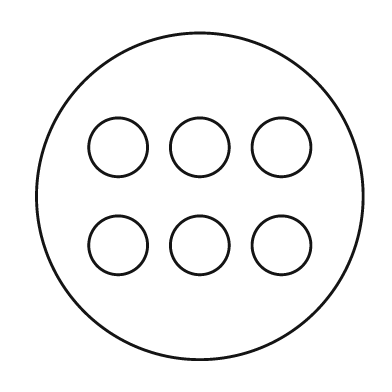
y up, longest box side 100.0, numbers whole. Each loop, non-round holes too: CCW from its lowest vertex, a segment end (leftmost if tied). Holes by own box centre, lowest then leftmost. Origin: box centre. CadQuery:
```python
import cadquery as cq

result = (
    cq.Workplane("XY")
    .moveTo(0.0, 0.0)
    .circle(50.0)
    .moveTo(-25.0, -15.0)
    .circle(9.0)
    .moveTo(0.0, -15.0)
    .circle(9.0)
    .moveTo(25.0, -15.0)
    .circle(9.0)
    .moveTo(-25.0, 15.0)
    .circle(9.0)
    .moveTo(0.0, 15.0)
    .circle(9.0)
    .moveTo(25.0, 15.0)
    .circle(9.0)
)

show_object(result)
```